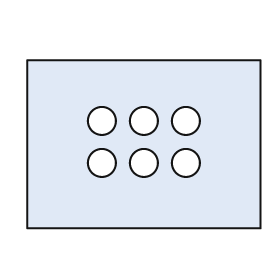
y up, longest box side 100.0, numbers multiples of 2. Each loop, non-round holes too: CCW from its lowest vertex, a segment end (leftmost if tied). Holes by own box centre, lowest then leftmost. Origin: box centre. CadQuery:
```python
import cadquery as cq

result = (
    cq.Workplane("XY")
    .moveTo(-50.0, -36.0)
    .lineTo(50.0, -36.0)
    .lineTo(50.0, 36.0)
    .lineTo(-50.0, 36.0)
    .close()
    .moveTo(-18.0, -8.0)
    .circle(6.0)
    .moveTo(0.0, -8.0)
    .circle(6.0)
    .moveTo(18.0, -8.0)
    .circle(6.0)
    .moveTo(-18.0, 10.0)
    .circle(6.0)
    .moveTo(0.0, 10.0)
    .circle(6.0)
    .moveTo(18.0, 10.0)
    .circle(6.0)
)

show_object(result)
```